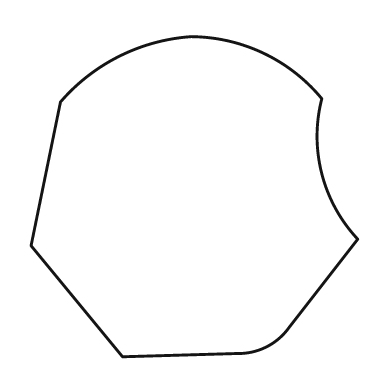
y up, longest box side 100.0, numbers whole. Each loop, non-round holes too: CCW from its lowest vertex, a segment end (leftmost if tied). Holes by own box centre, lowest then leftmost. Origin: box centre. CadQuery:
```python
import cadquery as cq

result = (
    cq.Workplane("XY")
    .moveTo(-22.0, -49.0)
    .lineTo(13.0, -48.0)
    .threePointArc((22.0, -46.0), (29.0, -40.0))
    .lineTo(50.0, -13.0)
    .threePointArc((39.0, 7.0), (39.0, 30.0))
    .threePointArc((21.0, 44.0), (-1.0, 49.0))
    .threePointArc((-23.0, 43.0), (-41.0, 29.0))
    .lineTo(-50.0, -15.0)
    .close()
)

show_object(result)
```